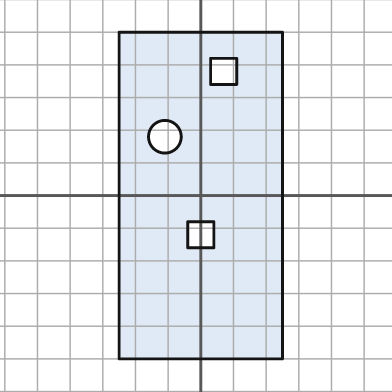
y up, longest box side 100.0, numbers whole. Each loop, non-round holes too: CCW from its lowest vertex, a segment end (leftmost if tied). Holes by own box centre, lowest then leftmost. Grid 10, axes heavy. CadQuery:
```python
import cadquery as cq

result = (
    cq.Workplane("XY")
    .moveTo(-25.0, -50.0)
    .lineTo(25.0, -50.0)
    .lineTo(25.0, 50.0)
    .lineTo(-25.0, 50.0)
    .close()
    .moveTo(-4.0, -16.0)
    .lineTo(4.0, -16.0)
    .lineTo(4.0, -8.0)
    .lineTo(-4.0, -8.0)
    .close()
    .moveTo(-11.0, 18.0)
    .circle(5.0)
    .moveTo(3.0, 34.0)
    .lineTo(11.0, 34.0)
    .lineTo(11.0, 42.0)
    .lineTo(3.0, 42.0)
    .close()
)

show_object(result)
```